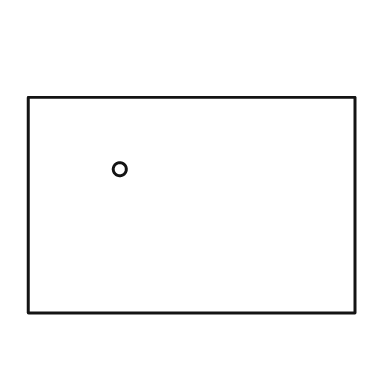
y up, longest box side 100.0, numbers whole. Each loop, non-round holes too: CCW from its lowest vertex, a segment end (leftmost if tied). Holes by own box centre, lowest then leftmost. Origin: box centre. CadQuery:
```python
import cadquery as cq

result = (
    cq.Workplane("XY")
    .moveTo(-50.0, -33.0)
    .lineTo(50.0, -33.0)
    .lineTo(50.0, 33.0)
    .lineTo(-50.0, 33.0)
    .close()
    .moveTo(-22.0, 11.0)
    .circle(2.0)
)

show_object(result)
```